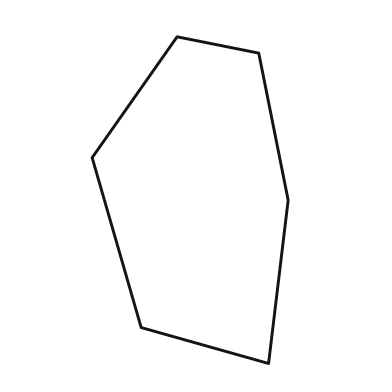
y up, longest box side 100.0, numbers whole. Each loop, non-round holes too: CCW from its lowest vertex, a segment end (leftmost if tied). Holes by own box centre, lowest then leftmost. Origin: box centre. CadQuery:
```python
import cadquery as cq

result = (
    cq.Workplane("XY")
    .moveTo(24.0, -50.0)
    .lineTo(30.0, 0.0)
    .lineTo(21.0, 45.0)
    .lineTo(-4.0, 50.0)
    .lineTo(-30.0, 13.0)
    .lineTo(-15.0, -39.0)
    .close()
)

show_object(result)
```